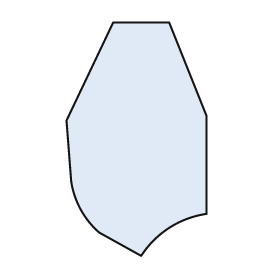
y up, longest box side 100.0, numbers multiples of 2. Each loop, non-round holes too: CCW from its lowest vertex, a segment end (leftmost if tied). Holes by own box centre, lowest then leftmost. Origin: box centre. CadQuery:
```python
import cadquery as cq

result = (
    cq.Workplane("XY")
    .moveTo(2.0, -50.0)
    .threePointArc((14.0, -38.0), (30.0, -32.0))
    .lineTo(30.0, 10.0)
    .lineTo(14.0, 50.0)
    .lineTo(-10.0, 50.0)
    .lineTo(-30.0, 8.0)
    .lineTo(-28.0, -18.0)
    .threePointArc((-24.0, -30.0), (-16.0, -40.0))
    .close()
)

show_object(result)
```